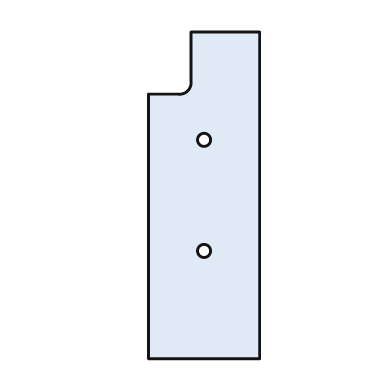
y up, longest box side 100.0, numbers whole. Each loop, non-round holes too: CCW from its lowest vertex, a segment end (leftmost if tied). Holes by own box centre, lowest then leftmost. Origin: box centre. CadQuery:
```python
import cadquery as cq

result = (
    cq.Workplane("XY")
    .moveTo(-17.0, -50.0)
    .lineTo(17.0, -50.0)
    .lineTo(17.0, 50.0)
    .lineTo(-4.0, 50.0)
    .lineTo(-4.0, 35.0)
    .threePointArc((-5.0, 32.0), (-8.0, 31.0))
    .lineTo(-17.0, 31.0)
    .close()
    .moveTo(0.0, -17.0)
    .circle(2.0)
    .moveTo(0.0, 17.0)
    .circle(2.0)
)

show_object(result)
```